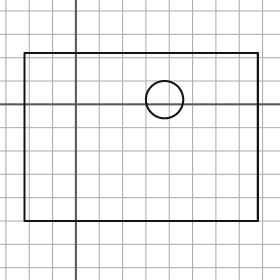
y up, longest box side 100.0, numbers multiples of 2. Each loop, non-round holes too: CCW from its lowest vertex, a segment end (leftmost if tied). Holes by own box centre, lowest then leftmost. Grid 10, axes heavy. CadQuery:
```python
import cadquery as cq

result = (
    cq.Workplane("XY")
    .moveTo(-22.0, -50.0)
    .lineTo(78.0, -50.0)
    .lineTo(78.0, 22.0)
    .lineTo(-22.0, 22.0)
    .close()
    .moveTo(38.0, 2.0)
    .circle(8.0)
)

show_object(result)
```